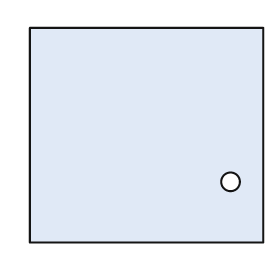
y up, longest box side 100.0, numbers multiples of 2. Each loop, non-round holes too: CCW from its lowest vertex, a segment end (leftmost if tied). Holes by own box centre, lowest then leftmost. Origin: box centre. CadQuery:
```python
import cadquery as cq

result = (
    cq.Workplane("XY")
    .moveTo(-50.0, -46.0)
    .lineTo(50.0, -46.0)
    .lineTo(50.0, 46.0)
    .lineTo(-50.0, 46.0)
    .close()
    .moveTo(36.0, -20.0)
    .circle(4.0)
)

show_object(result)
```